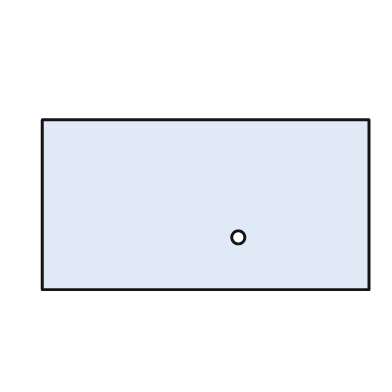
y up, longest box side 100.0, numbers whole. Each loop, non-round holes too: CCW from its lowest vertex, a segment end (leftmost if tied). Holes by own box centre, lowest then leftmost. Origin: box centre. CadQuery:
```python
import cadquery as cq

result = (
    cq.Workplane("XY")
    .moveTo(-50.0, -26.0)
    .lineTo(50.0, -26.0)
    .lineTo(50.0, 26.0)
    .lineTo(-50.0, 26.0)
    .close()
    .moveTo(10.0, -10.0)
    .circle(2.0)
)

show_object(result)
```